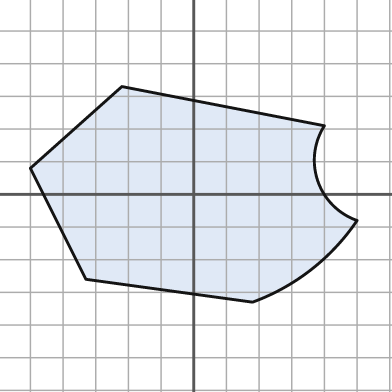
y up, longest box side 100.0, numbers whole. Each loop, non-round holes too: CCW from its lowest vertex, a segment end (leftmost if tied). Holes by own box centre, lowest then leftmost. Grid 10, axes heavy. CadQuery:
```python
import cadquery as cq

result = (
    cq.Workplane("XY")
    .moveTo(18.0, -33.0)
    .threePointArc((36.0, -23.0), (50.0, -8.0))
    .threePointArc((38.0, 4.0), (40.0, 21.0))
    .lineTo(-22.0, 33.0)
    .lineTo(-50.0, 8.0)
    .lineTo(-33.0, -26.0)
    .close()
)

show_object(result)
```